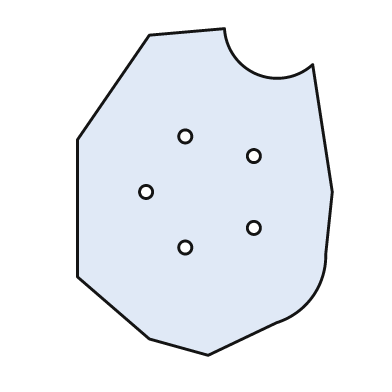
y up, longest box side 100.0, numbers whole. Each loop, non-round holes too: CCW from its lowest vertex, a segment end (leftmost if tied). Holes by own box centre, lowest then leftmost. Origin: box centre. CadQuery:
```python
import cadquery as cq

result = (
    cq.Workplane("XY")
    .moveTo(1.0, -50.0)
    .lineTo(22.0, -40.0)
    .threePointArc((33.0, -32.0), (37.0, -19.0))
    .lineTo(39.0, 0.0)
    .lineTo(33.0, 39.0)
    .threePointArc((16.0, 36.0), (6.0, 50.0))
    .lineTo(-17.0, 48.0)
    .lineTo(-39.0, 16.0)
    .lineTo(-39.0, -26.0)
    .lineTo(-17.0, -45.0)
    .close()
    .moveTo(-6.0, -17.0)
    .circle(2.0)
    .moveTo(15.0, -11.0)
    .circle(2.0)
    .moveTo(-18.0, 0.0)
    .circle(2.0)
    .moveTo(15.0, 11.0)
    .circle(2.0)
    .moveTo(-6.0, 17.0)
    .circle(2.0)
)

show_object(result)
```